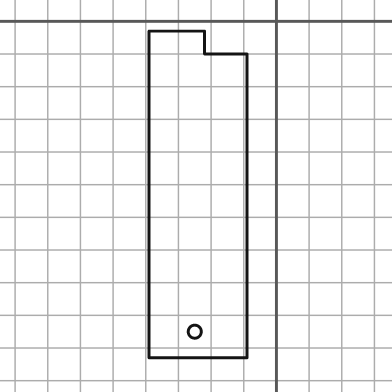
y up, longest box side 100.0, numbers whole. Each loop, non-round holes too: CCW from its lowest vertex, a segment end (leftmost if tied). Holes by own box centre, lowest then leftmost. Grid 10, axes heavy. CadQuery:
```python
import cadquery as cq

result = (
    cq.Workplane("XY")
    .moveTo(-39.0, -103.0)
    .lineTo(-9.0, -103.0)
    .lineTo(-9.0, -10.0)
    .lineTo(-22.0, -10.0)
    .lineTo(-22.0, -3.0)
    .lineTo(-39.0, -3.0)
    .close()
    .moveTo(-25.0, -95.0)
    .circle(2.0)
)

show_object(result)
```